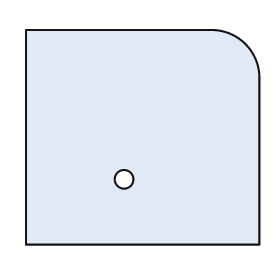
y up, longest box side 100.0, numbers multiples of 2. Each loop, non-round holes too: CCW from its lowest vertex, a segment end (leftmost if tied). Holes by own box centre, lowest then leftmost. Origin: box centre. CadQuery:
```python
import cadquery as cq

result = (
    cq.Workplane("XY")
    .moveTo(-50.0, -46.0)
    .lineTo(50.0, -46.0)
    .lineTo(50.0, 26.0)
    .threePointArc((44.0, 40.0), (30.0, 46.0))
    .lineTo(-50.0, 46.0)
    .close()
    .moveTo(-8.0, -18.0)
    .circle(4.0)
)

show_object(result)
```